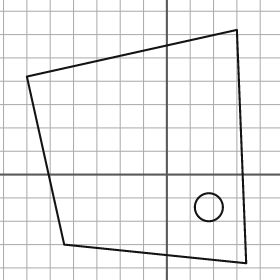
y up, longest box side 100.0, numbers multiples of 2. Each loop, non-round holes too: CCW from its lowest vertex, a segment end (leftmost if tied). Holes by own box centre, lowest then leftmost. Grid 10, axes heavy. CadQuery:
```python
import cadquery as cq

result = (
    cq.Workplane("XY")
    .moveTo(34.0, -38.0)
    .lineTo(30.0, 62.0)
    .lineTo(-60.0, 42.0)
    .lineTo(-44.0, -30.0)
    .close()
    .moveTo(18.0, -14.0)
    .circle(6.0)
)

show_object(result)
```